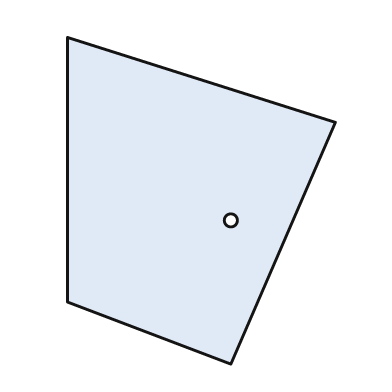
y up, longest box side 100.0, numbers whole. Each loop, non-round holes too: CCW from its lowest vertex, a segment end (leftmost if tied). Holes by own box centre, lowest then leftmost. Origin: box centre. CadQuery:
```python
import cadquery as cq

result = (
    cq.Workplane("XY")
    .moveTo(9.0, -50.0)
    .lineTo(41.0, 24.0)
    .lineTo(-41.0, 50.0)
    .lineTo(-41.0, -31.0)
    .close()
    .moveTo(9.0, -6.0)
    .circle(2.0)
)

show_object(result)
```